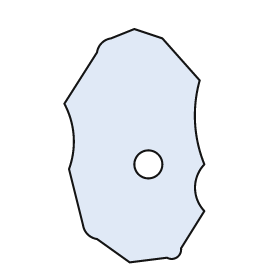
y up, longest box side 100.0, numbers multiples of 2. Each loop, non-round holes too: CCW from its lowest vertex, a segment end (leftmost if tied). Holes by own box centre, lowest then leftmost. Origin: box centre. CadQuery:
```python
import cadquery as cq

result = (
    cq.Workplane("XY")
    .moveTo(-2.0, -50.0)
    .lineTo(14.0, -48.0)
    .threePointArc((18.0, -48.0), (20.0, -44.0))
    .lineTo(30.0, -28.0)
    .threePointArc((26.0, -18.0), (30.0, -8.0))
    .threePointArc((26.0, 10.0), (28.0, 28.0))
    .lineTo(12.0, 46.0)
    .lineTo(0.0, 50.0)
    .lineTo(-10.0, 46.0)
    .threePointArc((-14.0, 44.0), (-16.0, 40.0))
    .lineTo(-30.0, 18.0)
    .threePointArc((-26.0, 4.0), (-28.0, -10.0))
    .lineTo(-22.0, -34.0)
    .threePointArc((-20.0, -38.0), (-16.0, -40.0))
    .close()
    .moveTo(6.0, -8.0)
    .circle(6.0)
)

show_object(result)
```